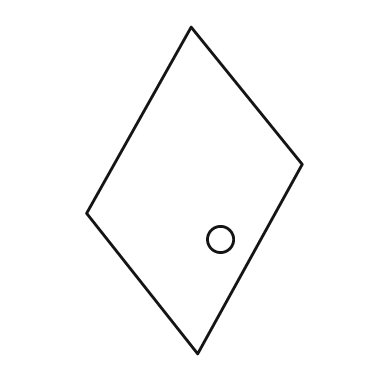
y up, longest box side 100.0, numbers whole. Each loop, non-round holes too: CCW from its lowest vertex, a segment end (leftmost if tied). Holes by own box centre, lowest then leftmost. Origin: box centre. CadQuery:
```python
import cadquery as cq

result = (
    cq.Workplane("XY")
    .moveTo(1.0, -50.0)
    .lineTo(33.0, 8.0)
    .lineTo(-1.0, 50.0)
    .lineTo(-33.0, -7.0)
    .close()
    .moveTo(8.0, -15.0)
    .circle(4.0)
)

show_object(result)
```